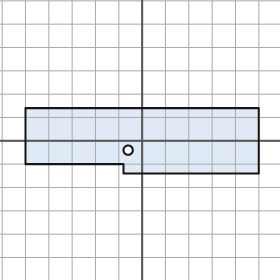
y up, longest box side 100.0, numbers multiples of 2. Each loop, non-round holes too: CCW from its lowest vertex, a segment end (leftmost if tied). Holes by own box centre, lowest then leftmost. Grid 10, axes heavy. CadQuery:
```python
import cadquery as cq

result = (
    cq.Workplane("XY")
    .moveTo(-8.0, -14.0)
    .lineTo(50.0, -14.0)
    .lineTo(50.0, 14.0)
    .lineTo(-50.0, 14.0)
    .lineTo(-50.0, -10.0)
    .lineTo(-8.0, -10.0)
    .close()
    .moveTo(-6.0, -4.0)
    .circle(2.0)
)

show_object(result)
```